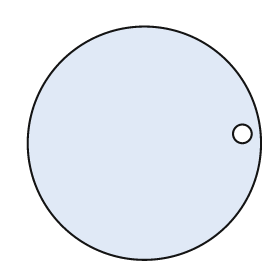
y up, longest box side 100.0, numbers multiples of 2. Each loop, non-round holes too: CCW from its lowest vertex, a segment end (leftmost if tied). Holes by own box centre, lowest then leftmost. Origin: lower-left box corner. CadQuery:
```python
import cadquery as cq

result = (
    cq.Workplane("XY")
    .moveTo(50.0, 50.0)
    .circle(50.0)
    .moveTo(92.0, 54.0)
    .circle(4.0)
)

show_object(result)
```